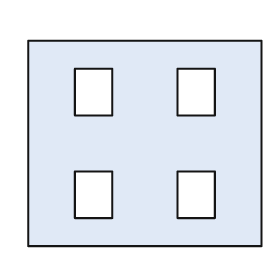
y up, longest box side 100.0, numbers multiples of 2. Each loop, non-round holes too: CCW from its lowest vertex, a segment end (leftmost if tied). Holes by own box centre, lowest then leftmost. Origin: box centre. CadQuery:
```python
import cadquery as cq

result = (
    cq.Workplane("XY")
    .moveTo(-50.0, -44.0)
    .lineTo(50.0, -44.0)
    .lineTo(50.0, 44.0)
    .lineTo(-50.0, 44.0)
    .close()
    .moveTo(-30.0, -32.0)
    .lineTo(-14.0, -32.0)
    .lineTo(-14.0, -12.0)
    .lineTo(-30.0, -12.0)
    .close()
    .moveTo(14.0, -32.0)
    .lineTo(30.0, -32.0)
    .lineTo(30.0, -12.0)
    .lineTo(14.0, -12.0)
    .close()
    .moveTo(-30.0, 12.0)
    .lineTo(-14.0, 12.0)
    .lineTo(-14.0, 32.0)
    .lineTo(-30.0, 32.0)
    .close()
    .moveTo(14.0, 12.0)
    .lineTo(30.0, 12.0)
    .lineTo(30.0, 32.0)
    .lineTo(14.0, 32.0)
    .close()
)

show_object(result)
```